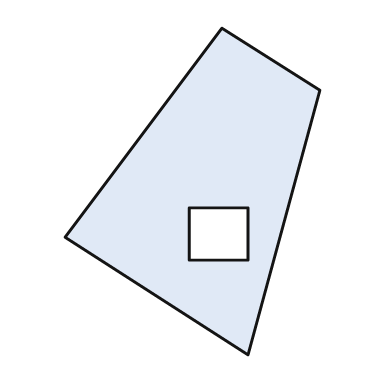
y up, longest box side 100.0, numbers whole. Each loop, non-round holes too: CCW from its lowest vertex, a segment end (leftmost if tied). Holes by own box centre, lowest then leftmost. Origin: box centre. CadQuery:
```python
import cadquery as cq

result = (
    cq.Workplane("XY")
    .moveTo(17.0, -50.0)
    .lineTo(39.0, 31.0)
    .lineTo(9.0, 50.0)
    .lineTo(-39.0, -14.0)
    .close()
    .moveTo(-1.0, -21.0)
    .lineTo(17.0, -21.0)
    .lineTo(17.0, -5.0)
    .lineTo(-1.0, -5.0)
    .close()
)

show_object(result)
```